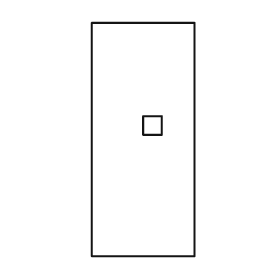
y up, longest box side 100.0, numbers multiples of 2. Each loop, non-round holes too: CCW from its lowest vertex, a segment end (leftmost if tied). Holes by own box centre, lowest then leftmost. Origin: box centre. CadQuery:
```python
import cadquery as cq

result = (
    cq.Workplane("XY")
    .moveTo(-22.0, -50.0)
    .lineTo(22.0, -50.0)
    .lineTo(22.0, 50.0)
    .lineTo(-22.0, 50.0)
    .close()
    .moveTo(0.0, 2.0)
    .lineTo(8.0, 2.0)
    .lineTo(8.0, 10.0)
    .lineTo(0.0, 10.0)
    .close()
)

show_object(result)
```